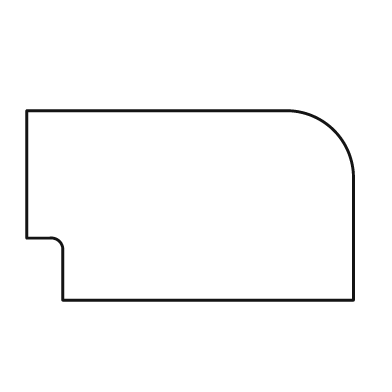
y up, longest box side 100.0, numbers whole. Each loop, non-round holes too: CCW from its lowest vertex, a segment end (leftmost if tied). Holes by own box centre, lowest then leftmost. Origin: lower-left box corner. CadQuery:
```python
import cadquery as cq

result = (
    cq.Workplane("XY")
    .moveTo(11.0, 0.0)
    .lineTo(100.0, 0.0)
    .lineTo(100.0, 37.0)
    .threePointArc((94.0, 52.0), (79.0, 58.0))
    .lineTo(0.0, 58.0)
    .lineTo(0.0, 19.0)
    .lineTo(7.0, 19.0)
    .threePointArc((10.0, 18.0), (11.0, 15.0))
    .close()
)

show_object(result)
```